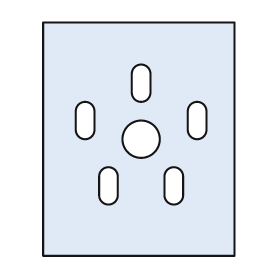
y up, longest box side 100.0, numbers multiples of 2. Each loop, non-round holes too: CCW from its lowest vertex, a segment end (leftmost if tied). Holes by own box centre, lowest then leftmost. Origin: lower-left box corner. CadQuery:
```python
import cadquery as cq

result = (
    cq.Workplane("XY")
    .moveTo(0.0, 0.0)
    .lineTo(82.0, 0.0)
    .lineTo(82.0, 100.0)
    .lineTo(0.0, 100.0)
    .close()
    .moveTo(24.0, 26.0)
    .threePointArc((28.0, 22.0), (32.0, 26.0))
    .lineTo(32.0, 34.0)
    .threePointArc((28.0, 38.0), (24.0, 34.0))
    .close()
    .moveTo(52.0, 26.0)
    .threePointArc((56.0, 22.0), (60.0, 26.0))
    .lineTo(60.0, 34.0)
    .threePointArc((56.0, 38.0), (52.0, 34.0))
    .close()
    .moveTo(42.0, 50.0)
    .circle(8.0)
    .moveTo(14.0, 54.0)
    .threePointArc((18.0, 50.0), (22.0, 54.0))
    .lineTo(22.0, 62.0)
    .threePointArc((18.0, 66.0), (14.0, 62.0))
    .close()
    .moveTo(62.0, 54.0)
    .threePointArc((66.0, 50.0), (70.0, 54.0))
    .lineTo(70.0, 62.0)
    .threePointArc((66.0, 66.0), (62.0, 62.0))
    .close()
    .moveTo(38.0, 70.0)
    .threePointArc((42.0, 66.0), (46.0, 70.0))
    .lineTo(46.0, 78.0)
    .threePointArc((42.0, 82.0), (38.0, 78.0))
    .close()
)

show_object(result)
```